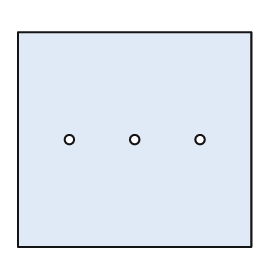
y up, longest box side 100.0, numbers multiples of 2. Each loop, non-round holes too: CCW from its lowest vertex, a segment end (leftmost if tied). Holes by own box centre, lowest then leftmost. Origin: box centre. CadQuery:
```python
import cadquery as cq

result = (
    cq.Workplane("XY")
    .moveTo(-50.0, -46.0)
    .lineTo(50.0, -46.0)
    .lineTo(50.0, 46.0)
    .lineTo(-50.0, 46.0)
    .close()
    .moveTo(-28.0, 0.0)
    .circle(2.0)
    .moveTo(0.0, 0.0)
    .circle(2.0)
    .moveTo(28.0, 0.0)
    .circle(2.0)
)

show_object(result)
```